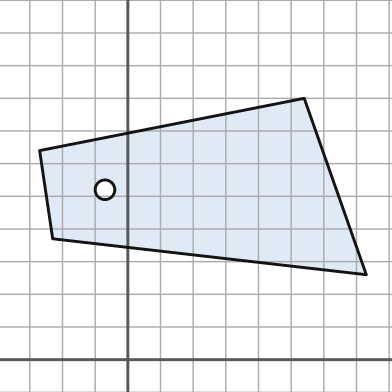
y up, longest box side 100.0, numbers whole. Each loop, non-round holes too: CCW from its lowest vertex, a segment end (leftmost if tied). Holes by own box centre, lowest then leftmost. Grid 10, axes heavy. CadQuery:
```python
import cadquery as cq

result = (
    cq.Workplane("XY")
    .moveTo(73.0, 26.0)
    .lineTo(54.0, 80.0)
    .lineTo(-27.0, 64.0)
    .lineTo(-23.0, 37.0)
    .close()
    .moveTo(-7.0, 52.0)
    .circle(3.0)
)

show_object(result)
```